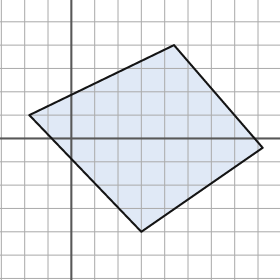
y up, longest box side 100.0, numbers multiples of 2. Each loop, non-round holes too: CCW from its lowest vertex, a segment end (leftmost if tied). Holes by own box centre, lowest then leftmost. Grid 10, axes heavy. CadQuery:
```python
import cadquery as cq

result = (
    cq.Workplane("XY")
    .moveTo(30.0, -40.0)
    .lineTo(82.0, -4.0)
    .lineTo(44.0, 40.0)
    .lineTo(-18.0, 10.0)
    .close()
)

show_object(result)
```